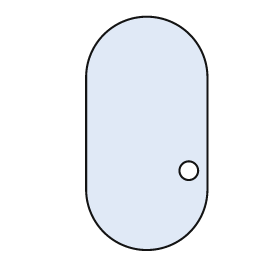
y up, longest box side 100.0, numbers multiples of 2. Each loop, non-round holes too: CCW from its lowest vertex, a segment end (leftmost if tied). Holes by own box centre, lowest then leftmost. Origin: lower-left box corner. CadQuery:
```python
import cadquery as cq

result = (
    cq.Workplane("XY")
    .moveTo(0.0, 26.0)
    .threePointArc((26.0, 0.0), (52.0, 26.0))
    .lineTo(52.0, 74.0)
    .threePointArc((26.0, 100.0), (0.0, 74.0))
    .close()
    .moveTo(44.0, 34.0)
    .circle(4.0)
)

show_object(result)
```